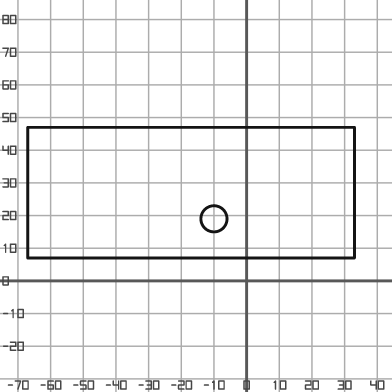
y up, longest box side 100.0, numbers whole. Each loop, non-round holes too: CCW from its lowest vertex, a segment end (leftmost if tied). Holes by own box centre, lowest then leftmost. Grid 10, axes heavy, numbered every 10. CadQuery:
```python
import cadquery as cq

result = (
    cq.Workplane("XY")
    .moveTo(-67.0, 7.0)
    .lineTo(33.0, 7.0)
    .lineTo(33.0, 47.0)
    .lineTo(-67.0, 47.0)
    .close()
    .moveTo(-10.0, 19.0)
    .circle(4.0)
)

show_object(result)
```